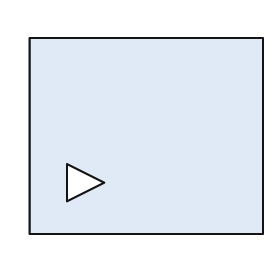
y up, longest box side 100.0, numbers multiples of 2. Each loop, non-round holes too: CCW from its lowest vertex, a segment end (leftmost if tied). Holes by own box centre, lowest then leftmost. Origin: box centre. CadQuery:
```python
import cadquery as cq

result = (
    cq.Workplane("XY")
    .moveTo(-50.0, -42.0)
    .lineTo(50.0, -42.0)
    .lineTo(50.0, 42.0)
    .lineTo(-50.0, 42.0)
    .close()
    .moveTo(-34.0, -28.0)
    .lineTo(-18.0, -20.0)
    .lineTo(-34.0, -12.0)
    .close()
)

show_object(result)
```